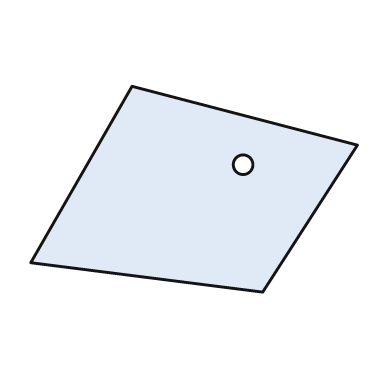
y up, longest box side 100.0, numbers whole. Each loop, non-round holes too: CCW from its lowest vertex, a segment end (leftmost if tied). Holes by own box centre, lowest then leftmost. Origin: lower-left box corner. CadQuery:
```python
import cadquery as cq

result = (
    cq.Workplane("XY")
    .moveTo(71.0, 0.0)
    .lineTo(100.0, 45.0)
    .lineTo(31.0, 63.0)
    .lineTo(0.0, 9.0)
    .close()
    .moveTo(65.0, 39.0)
    .circle(3.0)
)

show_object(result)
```